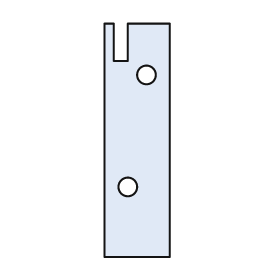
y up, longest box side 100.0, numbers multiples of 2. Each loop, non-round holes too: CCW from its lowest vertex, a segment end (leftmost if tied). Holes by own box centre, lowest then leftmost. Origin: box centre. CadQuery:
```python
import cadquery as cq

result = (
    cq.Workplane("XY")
    .moveTo(-14.0, -50.0)
    .lineTo(14.0, -50.0)
    .lineTo(14.0, 50.0)
    .lineTo(-4.0, 50.0)
    .lineTo(-4.0, 34.0)
    .lineTo(-10.0, 34.0)
    .lineTo(-10.0, 50.0)
    .lineTo(-14.0, 50.0)
    .close()
    .moveTo(-4.0, -20.0)
    .circle(4.0)
    .moveTo(4.0, 28.0)
    .circle(4.0)
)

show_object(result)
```